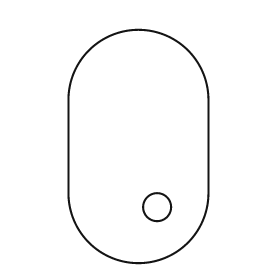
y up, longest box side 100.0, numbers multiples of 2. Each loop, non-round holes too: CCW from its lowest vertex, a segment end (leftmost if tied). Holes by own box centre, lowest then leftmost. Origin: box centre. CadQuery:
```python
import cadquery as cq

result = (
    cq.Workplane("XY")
    .moveTo(-30.0, -20.0)
    .threePointArc((0.0, -50.0), (30.0, -20.0))
    .lineTo(30.0, 20.0)
    .threePointArc((0.0, 50.0), (-30.0, 20.0))
    .close()
    .moveTo(8.0, -26.0)
    .circle(6.0)
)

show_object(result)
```